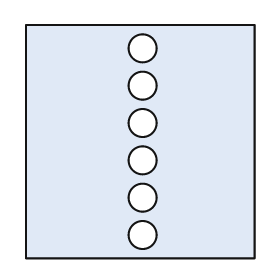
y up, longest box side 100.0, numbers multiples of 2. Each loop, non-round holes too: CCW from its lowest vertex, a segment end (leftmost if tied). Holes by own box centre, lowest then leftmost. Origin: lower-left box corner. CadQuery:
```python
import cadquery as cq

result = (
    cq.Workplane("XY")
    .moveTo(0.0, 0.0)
    .lineTo(98.0, 0.0)
    .lineTo(98.0, 100.0)
    .lineTo(0.0, 100.0)
    .close()
    .moveTo(50.0, 10.0)
    .circle(6.0)
    .moveTo(50.0, 26.0)
    .circle(6.0)
    .moveTo(50.0, 42.0)
    .circle(6.0)
    .moveTo(50.0, 58.0)
    .circle(6.0)
    .moveTo(50.0, 74.0)
    .circle(6.0)
    .moveTo(50.0, 90.0)
    .circle(6.0)
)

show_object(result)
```